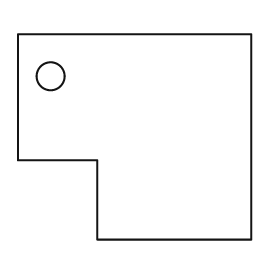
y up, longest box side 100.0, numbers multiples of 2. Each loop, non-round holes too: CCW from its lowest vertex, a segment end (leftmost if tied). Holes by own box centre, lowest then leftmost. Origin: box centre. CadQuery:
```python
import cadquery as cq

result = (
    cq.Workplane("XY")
    .moveTo(-16.0, -44.0)
    .lineTo(50.0, -44.0)
    .lineTo(50.0, 44.0)
    .lineTo(-50.0, 44.0)
    .lineTo(-50.0, -10.0)
    .lineTo(-16.0, -10.0)
    .close()
    .moveTo(-36.0, 26.0)
    .circle(6.0)
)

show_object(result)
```